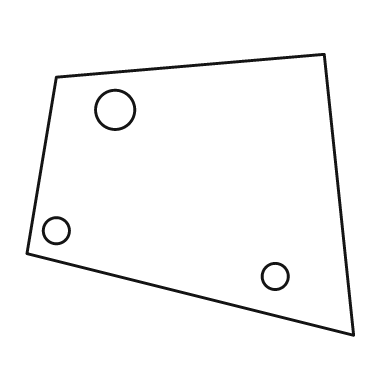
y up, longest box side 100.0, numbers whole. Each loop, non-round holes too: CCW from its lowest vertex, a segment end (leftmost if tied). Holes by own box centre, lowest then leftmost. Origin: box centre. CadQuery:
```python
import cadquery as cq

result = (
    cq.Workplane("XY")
    .moveTo(50.0, -43.0)
    .lineTo(41.0, 43.0)
    .lineTo(-41.0, 36.0)
    .lineTo(-50.0, -18.0)
    .close()
    .moveTo(26.0, -25.0)
    .circle(4.0)
    .moveTo(-41.0, -11.0)
    .circle(4.0)
    .moveTo(-23.0, 26.0)
    .circle(6.0)
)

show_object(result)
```